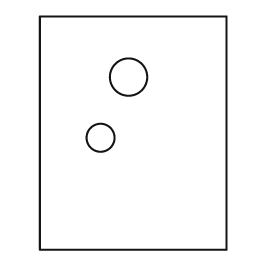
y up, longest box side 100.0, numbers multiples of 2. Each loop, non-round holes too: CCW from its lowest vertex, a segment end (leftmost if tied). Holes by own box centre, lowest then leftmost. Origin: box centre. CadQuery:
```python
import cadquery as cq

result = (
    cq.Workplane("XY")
    .moveTo(-40.0, -50.0)
    .lineTo(40.0, -50.0)
    .lineTo(40.0, 50.0)
    .lineTo(-40.0, 50.0)
    .close()
    .moveTo(-14.0, -2.0)
    .circle(6.0)
    .moveTo(-2.0, 24.0)
    .circle(8.0)
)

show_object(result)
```